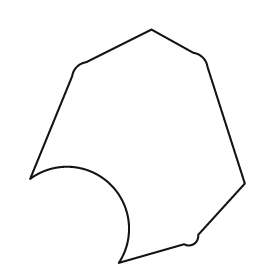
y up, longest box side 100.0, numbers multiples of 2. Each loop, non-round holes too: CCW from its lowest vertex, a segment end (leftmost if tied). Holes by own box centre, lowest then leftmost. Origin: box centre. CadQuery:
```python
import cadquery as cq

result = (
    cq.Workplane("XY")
    .moveTo(-8.0, -50.0)
    .lineTo(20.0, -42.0)
    .threePointArc((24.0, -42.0), (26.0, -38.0))
    .lineTo(46.0, -16.0)
    .lineTo(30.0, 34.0)
    .threePointArc((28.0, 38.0), (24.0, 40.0))
    .lineTo(6.0, 50.0)
    .lineTo(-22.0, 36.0)
    .threePointArc((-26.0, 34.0), (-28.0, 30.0))
    .lineTo(-46.0, -14.0)
    .threePointArc((-12.0, -16.0), (-8.0, -50.0))
    .close()
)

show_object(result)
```